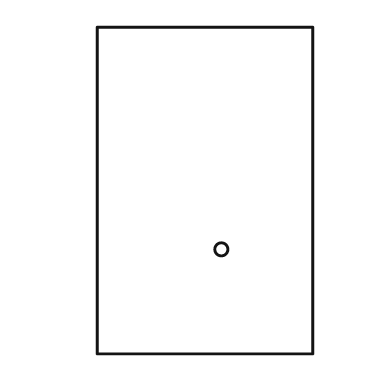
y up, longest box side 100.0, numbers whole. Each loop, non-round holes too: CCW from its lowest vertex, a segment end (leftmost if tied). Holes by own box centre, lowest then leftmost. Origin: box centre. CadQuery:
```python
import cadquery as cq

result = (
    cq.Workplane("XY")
    .moveTo(-33.0, -50.0)
    .lineTo(33.0, -50.0)
    .lineTo(33.0, 50.0)
    .lineTo(-33.0, 50.0)
    .close()
    .moveTo(5.0, -18.0)
    .circle(2.0)
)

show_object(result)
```